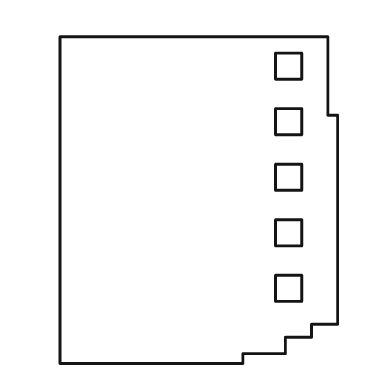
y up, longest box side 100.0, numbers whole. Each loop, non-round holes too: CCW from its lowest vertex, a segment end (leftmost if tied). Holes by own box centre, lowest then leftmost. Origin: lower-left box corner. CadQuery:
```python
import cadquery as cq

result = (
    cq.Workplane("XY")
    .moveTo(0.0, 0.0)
    .lineTo(56.0, 0.0)
    .lineTo(56.0, 3.0)
    .lineTo(69.0, 3.0)
    .lineTo(69.0, 8.0)
    .lineTo(77.0, 8.0)
    .lineTo(77.0, 12.0)
    .lineTo(85.0, 12.0)
    .lineTo(85.0, 76.0)
    .lineTo(82.0, 76.0)
    .lineTo(82.0, 100.0)
    .lineTo(0.0, 100.0)
    .close()
    .moveTo(66.0, 19.0)
    .lineTo(74.0, 19.0)
    .lineTo(74.0, 27.0)
    .lineTo(66.0, 27.0)
    .close()
    .moveTo(66.0, 36.0)
    .lineTo(74.0, 36.0)
    .lineTo(74.0, 44.0)
    .lineTo(66.0, 44.0)
    .close()
    .moveTo(66.0, 53.0)
    .lineTo(74.0, 53.0)
    .lineTo(74.0, 61.0)
    .lineTo(66.0, 61.0)
    .close()
    .moveTo(66.0, 70.0)
    .lineTo(74.0, 70.0)
    .lineTo(74.0, 78.0)
    .lineTo(66.0, 78.0)
    .close()
    .moveTo(66.0, 87.0)
    .lineTo(74.0, 87.0)
    .lineTo(74.0, 95.0)
    .lineTo(66.0, 95.0)
    .close()
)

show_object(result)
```